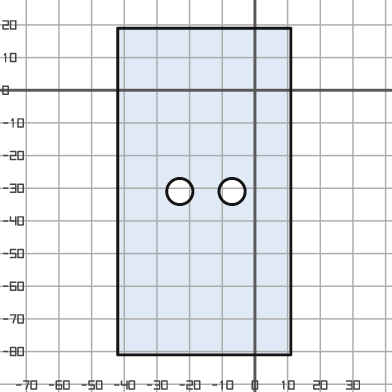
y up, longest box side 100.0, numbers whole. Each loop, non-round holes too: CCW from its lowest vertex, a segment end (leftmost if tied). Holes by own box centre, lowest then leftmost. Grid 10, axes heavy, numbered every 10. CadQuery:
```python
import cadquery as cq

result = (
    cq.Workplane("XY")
    .moveTo(-42.0, -81.0)
    .lineTo(11.0, -81.0)
    .lineTo(11.0, 19.0)
    .lineTo(-42.0, 19.0)
    .close()
    .moveTo(-23.0, -31.0)
    .circle(4.0)
    .moveTo(-7.0, -31.0)
    .circle(4.0)
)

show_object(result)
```